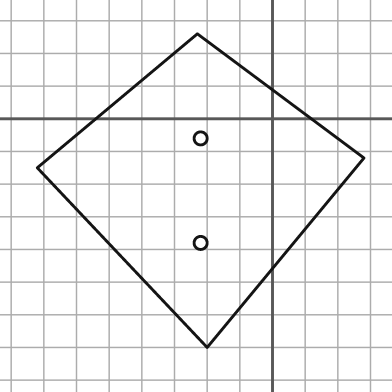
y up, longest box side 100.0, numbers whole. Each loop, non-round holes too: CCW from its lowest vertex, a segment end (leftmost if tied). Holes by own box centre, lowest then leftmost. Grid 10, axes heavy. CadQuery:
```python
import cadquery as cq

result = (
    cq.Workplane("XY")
    .moveTo(-20.0, -70.0)
    .lineTo(28.0, -12.0)
    .lineTo(-23.0, 26.0)
    .lineTo(-72.0, -15.0)
    .close()
    .moveTo(-22.0, -38.0)
    .circle(2.0)
    .moveTo(-22.0, -6.0)
    .circle(2.0)
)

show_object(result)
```